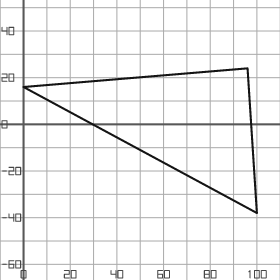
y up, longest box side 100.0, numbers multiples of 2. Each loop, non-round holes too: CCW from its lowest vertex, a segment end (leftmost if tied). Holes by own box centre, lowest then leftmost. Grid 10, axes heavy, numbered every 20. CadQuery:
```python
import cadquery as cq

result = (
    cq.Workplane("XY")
    .moveTo(100.0, -38.0)
    .lineTo(96.0, 24.0)
    .lineTo(0.0, 16.0)
    .close()
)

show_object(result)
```